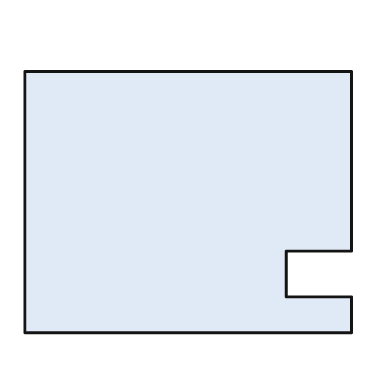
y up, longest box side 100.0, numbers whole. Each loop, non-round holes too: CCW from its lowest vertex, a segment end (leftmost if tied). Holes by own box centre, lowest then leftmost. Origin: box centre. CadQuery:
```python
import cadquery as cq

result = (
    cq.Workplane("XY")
    .moveTo(-50.0, -40.0)
    .lineTo(50.0, -40.0)
    .lineTo(50.0, -29.0)
    .lineTo(30.0, -29.0)
    .lineTo(30.0, -15.0)
    .lineTo(50.0, -15.0)
    .lineTo(50.0, 40.0)
    .lineTo(-50.0, 40.0)
    .close()
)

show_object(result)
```